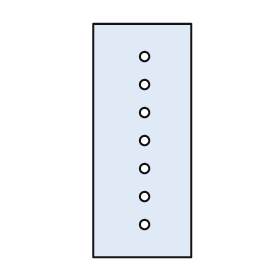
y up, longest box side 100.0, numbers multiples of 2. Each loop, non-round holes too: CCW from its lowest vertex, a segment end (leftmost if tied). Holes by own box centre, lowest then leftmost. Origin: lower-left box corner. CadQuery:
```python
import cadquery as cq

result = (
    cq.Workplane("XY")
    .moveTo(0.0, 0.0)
    .lineTo(42.0, 0.0)
    .lineTo(42.0, 100.0)
    .lineTo(0.0, 100.0)
    .close()
    .moveTo(22.0, 14.0)
    .circle(2.0)
    .moveTo(22.0, 26.0)
    .circle(2.0)
    .moveTo(22.0, 38.0)
    .circle(2.0)
    .moveTo(22.0, 50.0)
    .circle(2.0)
    .moveTo(22.0, 62.0)
    .circle(2.0)
    .moveTo(22.0, 74.0)
    .circle(2.0)
    .moveTo(22.0, 86.0)
    .circle(2.0)
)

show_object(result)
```